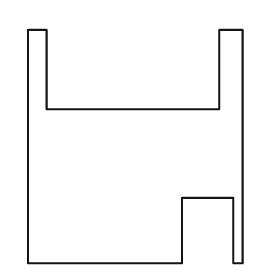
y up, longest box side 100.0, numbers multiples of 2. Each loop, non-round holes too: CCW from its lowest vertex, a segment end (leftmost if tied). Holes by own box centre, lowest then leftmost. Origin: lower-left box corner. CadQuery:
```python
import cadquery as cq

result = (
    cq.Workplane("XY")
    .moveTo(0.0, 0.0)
    .lineTo(66.0, 0.0)
    .lineTo(66.0, 28.0)
    .lineTo(88.0, 28.0)
    .lineTo(88.0, 0.0)
    .lineTo(92.0, 0.0)
    .lineTo(92.0, 100.0)
    .lineTo(82.0, 100.0)
    .lineTo(82.0, 66.0)
    .lineTo(8.0, 66.0)
    .lineTo(8.0, 100.0)
    .lineTo(0.0, 100.0)
    .close()
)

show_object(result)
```